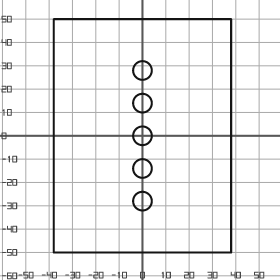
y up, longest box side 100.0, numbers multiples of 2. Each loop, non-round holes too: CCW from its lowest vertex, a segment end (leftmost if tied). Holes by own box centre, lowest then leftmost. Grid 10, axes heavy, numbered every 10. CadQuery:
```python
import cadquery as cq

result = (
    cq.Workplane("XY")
    .moveTo(-38.0, -50.0)
    .lineTo(38.0, -50.0)
    .lineTo(38.0, 50.0)
    .lineTo(-38.0, 50.0)
    .close()
    .moveTo(0.0, -28.0)
    .circle(4.0)
    .moveTo(0.0, -14.0)
    .circle(4.0)
    .moveTo(0.0, 0.0)
    .circle(4.0)
    .moveTo(0.0, 14.0)
    .circle(4.0)
    .moveTo(0.0, 28.0)
    .circle(4.0)
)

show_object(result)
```